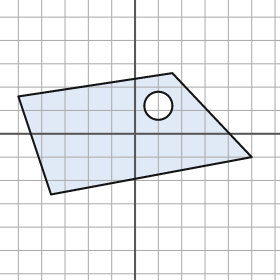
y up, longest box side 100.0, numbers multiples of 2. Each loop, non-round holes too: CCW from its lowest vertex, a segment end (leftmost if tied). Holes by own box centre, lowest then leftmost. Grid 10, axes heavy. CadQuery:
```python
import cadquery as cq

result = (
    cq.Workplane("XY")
    .moveTo(-36.0, -26.0)
    .lineTo(50.0, -10.0)
    .lineTo(16.0, 26.0)
    .lineTo(-50.0, 16.0)
    .close()
    .moveTo(10.0, 12.0)
    .circle(6.0)
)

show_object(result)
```